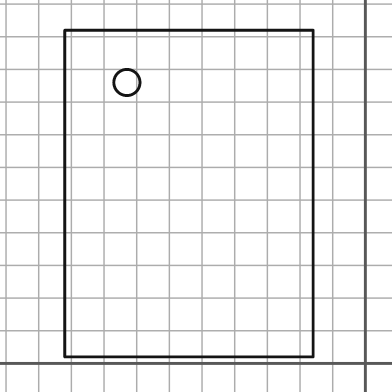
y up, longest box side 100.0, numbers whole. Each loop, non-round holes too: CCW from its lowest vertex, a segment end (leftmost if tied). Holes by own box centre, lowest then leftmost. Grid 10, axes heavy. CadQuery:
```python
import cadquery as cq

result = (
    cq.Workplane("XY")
    .moveTo(-92.0, 2.0)
    .lineTo(-16.0, 2.0)
    .lineTo(-16.0, 102.0)
    .lineTo(-92.0, 102.0)
    .close()
    .moveTo(-73.0, 86.0)
    .circle(4.0)
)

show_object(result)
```